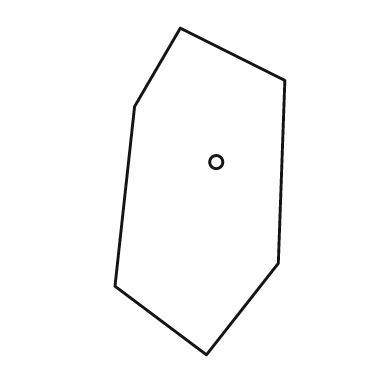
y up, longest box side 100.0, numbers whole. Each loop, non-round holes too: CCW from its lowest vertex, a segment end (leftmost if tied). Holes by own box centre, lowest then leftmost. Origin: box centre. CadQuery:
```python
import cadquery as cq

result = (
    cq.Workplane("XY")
    .moveTo(2.0, -50.0)
    .lineTo(24.0, -22.0)
    .lineTo(26.0, 34.0)
    .lineTo(-6.0, 50.0)
    .lineTo(-20.0, 26.0)
    .lineTo(-26.0, -29.0)
    .close()
    .moveTo(5.0, 9.0)
    .circle(2.0)
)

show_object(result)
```